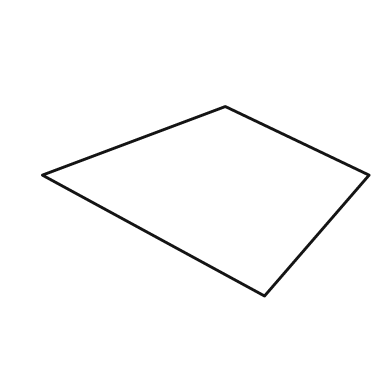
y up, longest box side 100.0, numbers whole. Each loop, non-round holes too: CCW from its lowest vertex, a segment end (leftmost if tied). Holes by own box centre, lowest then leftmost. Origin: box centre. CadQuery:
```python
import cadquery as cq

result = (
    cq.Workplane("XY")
    .moveTo(18.0, -29.0)
    .lineTo(50.0, 8.0)
    .lineTo(6.0, 29.0)
    .lineTo(-50.0, 8.0)
    .close()
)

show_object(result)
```